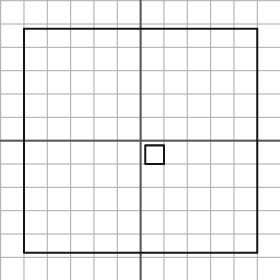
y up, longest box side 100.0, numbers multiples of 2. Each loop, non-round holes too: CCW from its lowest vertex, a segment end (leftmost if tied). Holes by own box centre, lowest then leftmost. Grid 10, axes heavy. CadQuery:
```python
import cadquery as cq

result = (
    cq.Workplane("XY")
    .moveTo(-50.0, -48.0)
    .lineTo(50.0, -48.0)
    .lineTo(50.0, 48.0)
    .lineTo(-50.0, 48.0)
    .close()
    .moveTo(2.0, -10.0)
    .lineTo(10.0, -10.0)
    .lineTo(10.0, -2.0)
    .lineTo(2.0, -2.0)
    .close()
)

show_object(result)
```